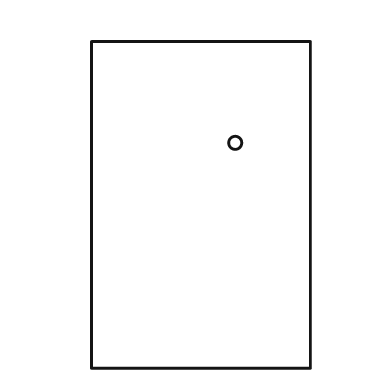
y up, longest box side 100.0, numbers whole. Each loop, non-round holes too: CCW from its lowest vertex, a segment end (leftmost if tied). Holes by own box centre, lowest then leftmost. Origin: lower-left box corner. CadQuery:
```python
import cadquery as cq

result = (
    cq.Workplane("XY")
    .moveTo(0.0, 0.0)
    .lineTo(67.0, 0.0)
    .lineTo(67.0, 100.0)
    .lineTo(0.0, 100.0)
    .close()
    .moveTo(44.0, 69.0)
    .circle(2.0)
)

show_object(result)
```